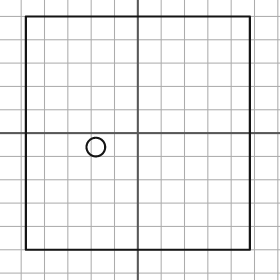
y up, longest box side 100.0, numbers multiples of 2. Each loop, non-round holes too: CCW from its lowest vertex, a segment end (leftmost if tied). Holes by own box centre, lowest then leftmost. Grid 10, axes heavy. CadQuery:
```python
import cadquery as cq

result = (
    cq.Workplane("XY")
    .moveTo(-48.0, -50.0)
    .lineTo(48.0, -50.0)
    .lineTo(48.0, 50.0)
    .lineTo(-48.0, 50.0)
    .close()
    .moveTo(-18.0, -6.0)
    .circle(4.0)
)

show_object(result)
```